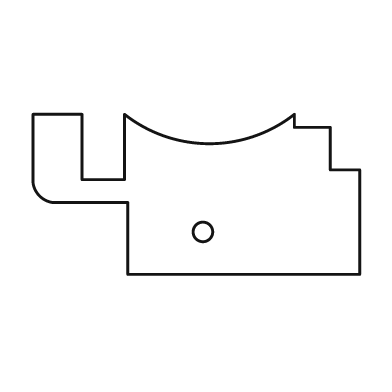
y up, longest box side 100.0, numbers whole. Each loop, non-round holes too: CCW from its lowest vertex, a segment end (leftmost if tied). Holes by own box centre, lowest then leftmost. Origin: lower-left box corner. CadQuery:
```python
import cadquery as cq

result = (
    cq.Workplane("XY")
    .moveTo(29.0, 0.0)
    .lineTo(100.0, 0.0)
    .lineTo(100.0, 32.0)
    .lineTo(91.0, 32.0)
    .lineTo(91.0, 45.0)
    .lineTo(80.0, 45.0)
    .lineTo(80.0, 49.0)
    .threePointArc((54.0, 40.0), (28.0, 49.0))
    .lineTo(28.0, 29.0)
    .lineTo(15.0, 29.0)
    .lineTo(15.0, 49.0)
    .lineTo(0.0, 49.0)
    .lineTo(0.0, 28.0)
    .threePointArc((2.0, 24.0), (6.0, 22.0))
    .lineTo(29.0, 22.0)
    .close()
    .moveTo(52.0, 13.0)
    .circle(3.0)
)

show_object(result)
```